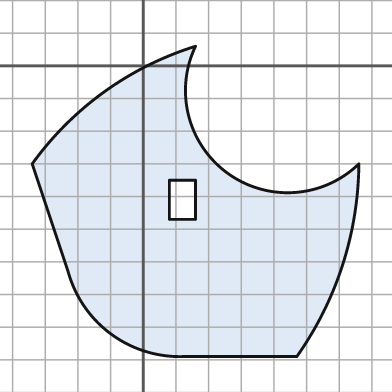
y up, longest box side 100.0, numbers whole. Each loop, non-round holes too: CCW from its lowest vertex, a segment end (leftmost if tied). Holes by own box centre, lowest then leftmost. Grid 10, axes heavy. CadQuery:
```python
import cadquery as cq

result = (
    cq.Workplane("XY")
    .moveTo(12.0, -89.0)
    .lineTo(47.0, -89.0)
    .threePointArc((61.0, -61.0), (66.0, -30.0))
    .threePointArc((26.0, -33.0), (16.0, 6.0))
    .threePointArc((-12.0, -8.0), (-34.0, -30.0))
    .lineTo(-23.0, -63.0)
    .threePointArc((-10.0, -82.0), (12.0, -89.0))
    .close()
    .moveTo(8.0, -47.0)
    .lineTo(16.0, -47.0)
    .lineTo(16.0, -35.0)
    .lineTo(8.0, -35.0)
    .close()
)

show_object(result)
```